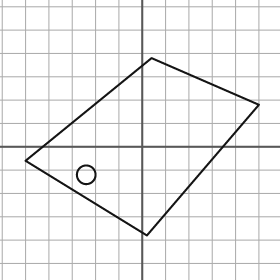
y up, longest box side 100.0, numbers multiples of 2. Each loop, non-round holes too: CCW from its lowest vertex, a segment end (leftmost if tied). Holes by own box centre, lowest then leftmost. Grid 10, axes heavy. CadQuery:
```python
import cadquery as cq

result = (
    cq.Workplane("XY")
    .moveTo(2.0, -38.0)
    .lineTo(50.0, 18.0)
    .lineTo(4.0, 38.0)
    .lineTo(-50.0, -6.0)
    .close()
    .moveTo(-24.0, -12.0)
    .circle(4.0)
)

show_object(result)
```